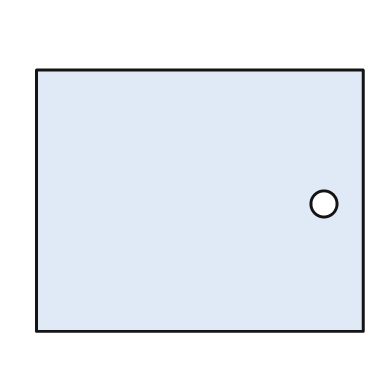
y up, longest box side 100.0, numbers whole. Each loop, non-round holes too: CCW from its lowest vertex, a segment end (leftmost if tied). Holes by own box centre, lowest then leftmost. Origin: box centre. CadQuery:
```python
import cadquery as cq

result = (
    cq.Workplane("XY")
    .moveTo(-50.0, -40.0)
    .lineTo(50.0, -40.0)
    .lineTo(50.0, 40.0)
    .lineTo(-50.0, 40.0)
    .close()
    .moveTo(38.0, -1.0)
    .circle(4.0)
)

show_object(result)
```